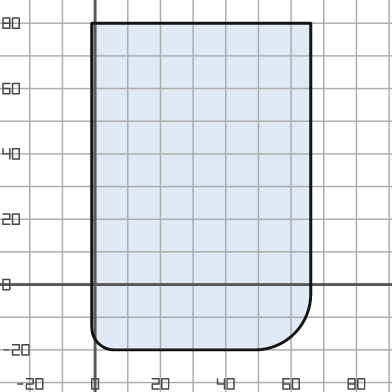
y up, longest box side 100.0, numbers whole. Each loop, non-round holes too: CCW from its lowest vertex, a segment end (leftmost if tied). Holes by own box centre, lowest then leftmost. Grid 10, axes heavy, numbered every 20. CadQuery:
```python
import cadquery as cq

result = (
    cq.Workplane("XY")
    .moveTo(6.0, -20.0)
    .lineTo(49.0, -20.0)
    .threePointArc((61.0, -15.0), (66.0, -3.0))
    .lineTo(66.0, 80.0)
    .lineTo(-1.0, 80.0)
    .lineTo(-1.0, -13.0)
    .threePointArc((1.0, -18.0), (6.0, -20.0))
    .close()
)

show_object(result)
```